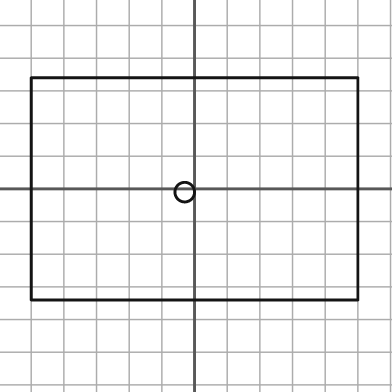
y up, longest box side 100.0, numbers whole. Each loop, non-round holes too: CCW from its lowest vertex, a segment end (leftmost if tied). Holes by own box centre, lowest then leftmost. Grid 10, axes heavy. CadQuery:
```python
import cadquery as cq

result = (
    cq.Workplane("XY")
    .moveTo(-50.0, -34.0)
    .lineTo(50.0, -34.0)
    .lineTo(50.0, 34.0)
    .lineTo(-50.0, 34.0)
    .close()
    .moveTo(-3.0, -1.0)
    .circle(3.0)
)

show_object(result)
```